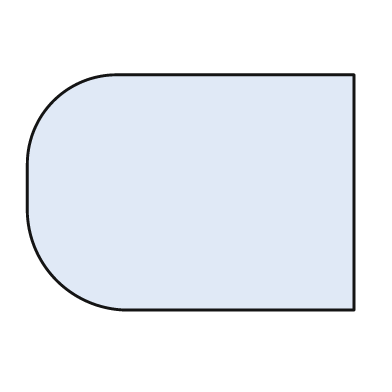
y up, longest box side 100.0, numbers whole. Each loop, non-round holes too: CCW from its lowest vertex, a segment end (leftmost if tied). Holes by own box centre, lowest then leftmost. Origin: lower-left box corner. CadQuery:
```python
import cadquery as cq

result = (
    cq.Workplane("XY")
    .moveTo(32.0, 0.0)
    .lineTo(100.0, 0.0)
    .lineTo(100.0, 72.0)
    .lineTo(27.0, 72.0)
    .threePointArc((8.0, 64.0), (0.0, 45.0))
    .lineTo(0.0, 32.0)
    .threePointArc((9.0, 9.0), (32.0, 0.0))
    .close()
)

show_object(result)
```